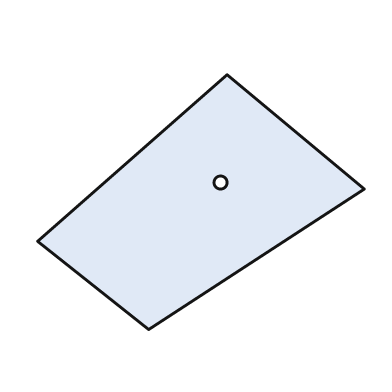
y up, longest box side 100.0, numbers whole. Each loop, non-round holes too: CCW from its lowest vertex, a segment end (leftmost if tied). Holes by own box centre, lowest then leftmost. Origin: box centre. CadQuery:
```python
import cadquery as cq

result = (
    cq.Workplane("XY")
    .moveTo(-16.0, -39.0)
    .lineTo(50.0, 4.0)
    .lineTo(8.0, 39.0)
    .lineTo(-50.0, -12.0)
    .close()
    .moveTo(6.0, 6.0)
    .circle(2.0)
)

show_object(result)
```